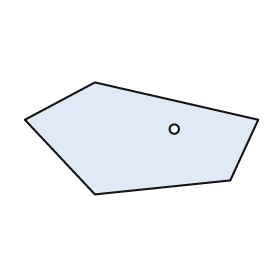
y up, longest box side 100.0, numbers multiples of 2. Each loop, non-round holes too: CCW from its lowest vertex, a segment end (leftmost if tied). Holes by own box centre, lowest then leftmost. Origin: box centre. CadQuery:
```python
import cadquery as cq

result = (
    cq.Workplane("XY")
    .moveTo(-20.0, -24.0)
    .lineTo(38.0, -18.0)
    .lineTo(50.0, 8.0)
    .lineTo(-20.0, 24.0)
    .lineTo(-50.0, 8.0)
    .close()
    .moveTo(14.0, 4.0)
    .circle(2.0)
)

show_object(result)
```